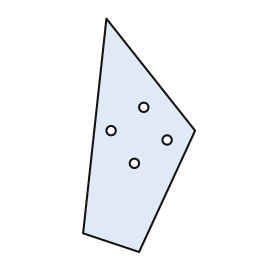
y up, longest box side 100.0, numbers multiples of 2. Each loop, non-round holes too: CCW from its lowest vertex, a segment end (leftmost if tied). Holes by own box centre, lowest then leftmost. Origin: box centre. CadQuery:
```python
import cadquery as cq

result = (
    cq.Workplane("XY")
    .moveTo(0.0, -50.0)
    .lineTo(24.0, 2.0)
    .lineTo(-14.0, 50.0)
    .lineTo(-24.0, -42.0)
    .close()
    .moveTo(-2.0, -12.0)
    .circle(2.0)
    .moveTo(12.0, -2.0)
    .circle(2.0)
    .moveTo(-12.0, 2.0)
    .circle(2.0)
    .moveTo(2.0, 12.0)
    .circle(2.0)
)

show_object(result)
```